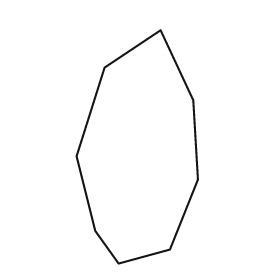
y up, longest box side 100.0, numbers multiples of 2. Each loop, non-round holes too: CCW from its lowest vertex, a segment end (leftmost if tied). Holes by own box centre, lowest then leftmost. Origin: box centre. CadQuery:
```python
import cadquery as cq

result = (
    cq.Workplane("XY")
    .moveTo(-8.0, -50.0)
    .lineTo(14.0, -44.0)
    .lineTo(26.0, -14.0)
    .lineTo(24.0, 20.0)
    .lineTo(10.0, 50.0)
    .lineTo(-14.0, 34.0)
    .lineTo(-26.0, -4.0)
    .lineTo(-18.0, -36.0)
    .close()
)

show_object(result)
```